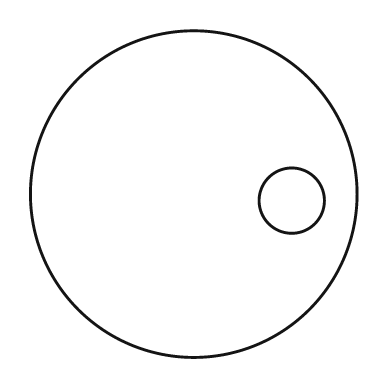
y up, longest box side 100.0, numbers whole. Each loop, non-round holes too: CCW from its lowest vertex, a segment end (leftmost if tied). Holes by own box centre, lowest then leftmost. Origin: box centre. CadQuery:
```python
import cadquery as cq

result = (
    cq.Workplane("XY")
    .moveTo(0.0, 0.0)
    .circle(50.0)
    .moveTo(30.0, -2.0)
    .circle(10.0)
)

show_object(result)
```